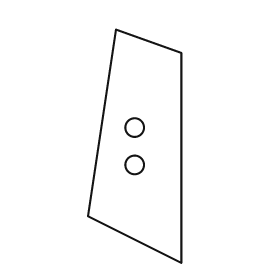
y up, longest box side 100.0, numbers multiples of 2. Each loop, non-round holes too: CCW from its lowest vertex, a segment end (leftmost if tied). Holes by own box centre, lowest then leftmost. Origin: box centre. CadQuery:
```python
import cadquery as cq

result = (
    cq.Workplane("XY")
    .moveTo(20.0, -50.0)
    .lineTo(20.0, 40.0)
    .lineTo(-8.0, 50.0)
    .lineTo(-20.0, -30.0)
    .close()
    .moveTo(0.0, -8.0)
    .circle(4.0)
    .moveTo(0.0, 8.0)
    .circle(4.0)
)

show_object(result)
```